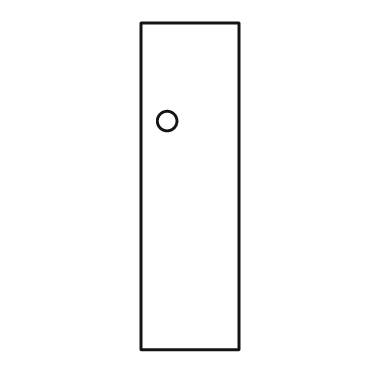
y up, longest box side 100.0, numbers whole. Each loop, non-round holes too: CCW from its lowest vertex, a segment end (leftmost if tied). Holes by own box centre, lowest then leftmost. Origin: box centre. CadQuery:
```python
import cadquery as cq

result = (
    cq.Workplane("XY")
    .moveTo(-15.0, -50.0)
    .lineTo(15.0, -50.0)
    .lineTo(15.0, 50.0)
    .lineTo(-15.0, 50.0)
    .close()
    .moveTo(-7.0, 20.0)
    .circle(3.0)
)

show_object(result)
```